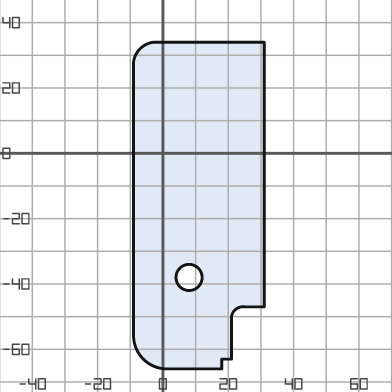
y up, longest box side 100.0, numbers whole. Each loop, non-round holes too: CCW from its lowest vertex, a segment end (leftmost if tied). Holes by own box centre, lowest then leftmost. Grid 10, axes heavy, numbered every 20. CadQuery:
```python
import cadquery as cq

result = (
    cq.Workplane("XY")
    .moveTo(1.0, -66.0)
    .lineTo(18.0, -66.0)
    .lineTo(18.0, -63.0)
    .lineTo(21.0, -63.0)
    .lineTo(21.0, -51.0)
    .threePointArc((22.0, -48.0), (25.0, -47.0))
    .lineTo(31.0, -47.0)
    .lineTo(31.0, 34.0)
    .lineTo(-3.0, 34.0)
    .threePointArc((-7.0, 32.0), (-9.0, 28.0))
    .lineTo(-9.0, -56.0)
    .threePointArc((-6.0, -63.0), (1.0, -66.0))
    .close()
    .moveTo(8.0, -38.0)
    .circle(4.0)
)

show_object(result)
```